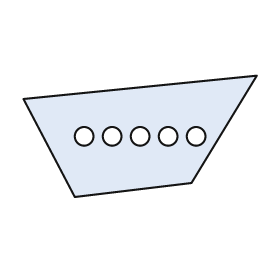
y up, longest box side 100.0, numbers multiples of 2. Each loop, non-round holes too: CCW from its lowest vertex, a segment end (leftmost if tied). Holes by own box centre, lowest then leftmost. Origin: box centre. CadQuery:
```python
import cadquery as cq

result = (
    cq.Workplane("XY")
    .moveTo(-28.0, -26.0)
    .lineTo(22.0, -20.0)
    .lineTo(50.0, 26.0)
    .lineTo(-50.0, 16.0)
    .close()
    .moveTo(-24.0, 0.0)
    .circle(4.0)
    .moveTo(-12.0, 0.0)
    .circle(4.0)
    .moveTo(0.0, 0.0)
    .circle(4.0)
    .moveTo(12.0, 0.0)
    .circle(4.0)
    .moveTo(24.0, 0.0)
    .circle(4.0)
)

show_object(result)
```